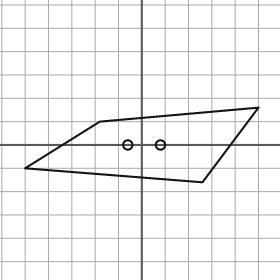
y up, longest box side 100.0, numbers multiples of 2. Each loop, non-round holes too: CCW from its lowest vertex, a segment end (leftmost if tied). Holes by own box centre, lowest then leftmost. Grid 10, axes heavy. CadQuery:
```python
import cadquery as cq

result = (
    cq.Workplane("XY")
    .moveTo(26.0, -16.0)
    .lineTo(50.0, 16.0)
    .lineTo(-18.0, 10.0)
    .lineTo(-50.0, -10.0)
    .close()
    .moveTo(-6.0, 0.0)
    .circle(2.0)
    .moveTo(8.0, 0.0)
    .circle(2.0)
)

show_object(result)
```